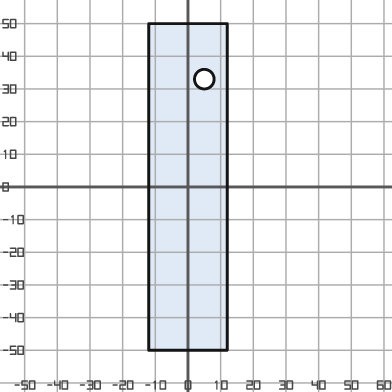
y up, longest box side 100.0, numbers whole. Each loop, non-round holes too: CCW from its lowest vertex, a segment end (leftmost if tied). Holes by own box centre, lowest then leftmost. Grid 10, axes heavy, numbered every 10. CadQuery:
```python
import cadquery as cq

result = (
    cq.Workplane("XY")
    .moveTo(-12.0, -50.0)
    .lineTo(12.0, -50.0)
    .lineTo(12.0, 50.0)
    .lineTo(-12.0, 50.0)
    .close()
    .moveTo(5.0, 33.0)
    .circle(3.0)
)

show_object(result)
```